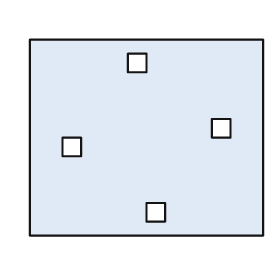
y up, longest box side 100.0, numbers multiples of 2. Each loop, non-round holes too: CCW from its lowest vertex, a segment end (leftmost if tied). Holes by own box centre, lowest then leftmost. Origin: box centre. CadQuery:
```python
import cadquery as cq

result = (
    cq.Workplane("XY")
    .moveTo(-50.0, -42.0)
    .lineTo(50.0, -42.0)
    .lineTo(50.0, 42.0)
    .lineTo(-50.0, 42.0)
    .close()
    .moveTo(0.0, -36.0)
    .lineTo(8.0, -36.0)
    .lineTo(8.0, -28.0)
    .lineTo(0.0, -28.0)
    .close()
    .moveTo(-36.0, -8.0)
    .lineTo(-28.0, -8.0)
    .lineTo(-28.0, 0.0)
    .lineTo(-36.0, 0.0)
    .close()
    .moveTo(28.0, 0.0)
    .lineTo(36.0, 0.0)
    .lineTo(36.0, 8.0)
    .lineTo(28.0, 8.0)
    .close()
    .moveTo(-8.0, 28.0)
    .lineTo(0.0, 28.0)
    .lineTo(0.0, 36.0)
    .lineTo(-8.0, 36.0)
    .close()
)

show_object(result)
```